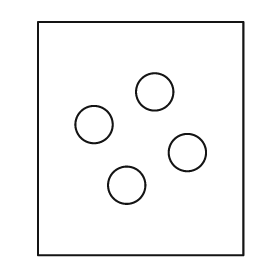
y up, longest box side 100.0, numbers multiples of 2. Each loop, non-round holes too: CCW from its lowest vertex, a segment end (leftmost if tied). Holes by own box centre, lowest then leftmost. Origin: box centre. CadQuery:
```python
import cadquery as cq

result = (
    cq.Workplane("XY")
    .moveTo(-44.0, -50.0)
    .lineTo(44.0, -50.0)
    .lineTo(44.0, 50.0)
    .lineTo(-44.0, 50.0)
    .close()
    .moveTo(-6.0, -20.0)
    .circle(8.0)
    .moveTo(20.0, -6.0)
    .circle(8.0)
    .moveTo(-20.0, 6.0)
    .circle(8.0)
    .moveTo(6.0, 20.0)
    .circle(8.0)
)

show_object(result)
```